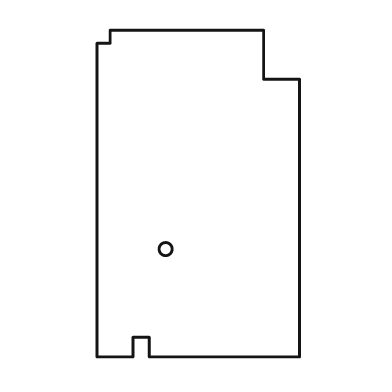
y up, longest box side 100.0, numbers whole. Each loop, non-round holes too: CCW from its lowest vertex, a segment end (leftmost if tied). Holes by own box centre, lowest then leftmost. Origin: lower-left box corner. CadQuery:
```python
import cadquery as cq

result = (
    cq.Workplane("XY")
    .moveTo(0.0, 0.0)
    .lineTo(11.0, 0.0)
    .lineTo(11.0, 6.0)
    .lineTo(16.0, 6.0)
    .lineTo(16.0, 0.0)
    .lineTo(62.0, 0.0)
    .lineTo(62.0, 85.0)
    .lineTo(51.0, 85.0)
    .lineTo(51.0, 100.0)
    .lineTo(4.0, 100.0)
    .lineTo(4.0, 96.0)
    .lineTo(0.0, 96.0)
    .close()
    .moveTo(21.0, 33.0)
    .circle(2.0)
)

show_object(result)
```